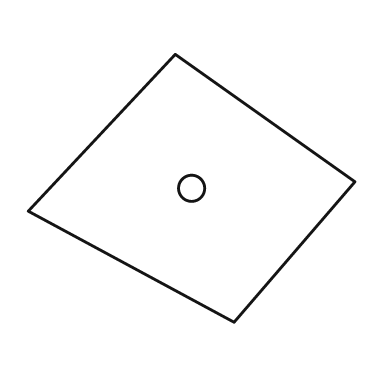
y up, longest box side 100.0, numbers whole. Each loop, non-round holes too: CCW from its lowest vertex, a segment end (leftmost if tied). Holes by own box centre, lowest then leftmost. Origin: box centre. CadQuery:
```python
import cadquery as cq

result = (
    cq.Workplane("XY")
    .moveTo(13.0, -41.0)
    .lineTo(50.0, 2.0)
    .lineTo(-5.0, 41.0)
    .lineTo(-50.0, -7.0)
    .close()
    .moveTo(0.0, 0.0)
    .circle(4.0)
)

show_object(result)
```